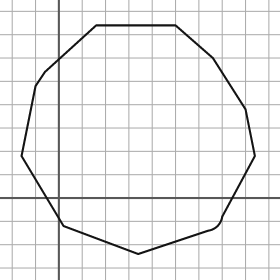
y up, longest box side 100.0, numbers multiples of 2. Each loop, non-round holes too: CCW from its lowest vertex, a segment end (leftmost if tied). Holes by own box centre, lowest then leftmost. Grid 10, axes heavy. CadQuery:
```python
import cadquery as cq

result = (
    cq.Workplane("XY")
    .moveTo(34.0, -24.0)
    .lineTo(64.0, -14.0)
    .threePointArc((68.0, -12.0), (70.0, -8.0))
    .lineTo(84.0, 18.0)
    .lineTo(80.0, 38.0)
    .lineTo(66.0, 60.0)
    .lineTo(50.0, 74.0)
    .lineTo(16.0, 74.0)
    .lineTo(-6.0, 54.0)
    .lineTo(-10.0, 48.0)
    .lineTo(-16.0, 18.0)
    .lineTo(2.0, -12.0)
    .close()
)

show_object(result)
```